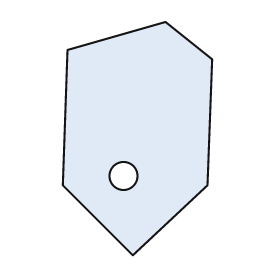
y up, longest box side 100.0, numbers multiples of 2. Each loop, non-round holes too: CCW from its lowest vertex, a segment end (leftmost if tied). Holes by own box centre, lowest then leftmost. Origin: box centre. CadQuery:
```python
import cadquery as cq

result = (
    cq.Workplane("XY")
    .moveTo(-2.0, -50.0)
    .lineTo(30.0, -20.0)
    .lineTo(32.0, 34.0)
    .lineTo(12.0, 50.0)
    .lineTo(-30.0, 38.0)
    .lineTo(-32.0, -20.0)
    .close()
    .moveTo(-6.0, -16.0)
    .circle(6.0)
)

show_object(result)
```